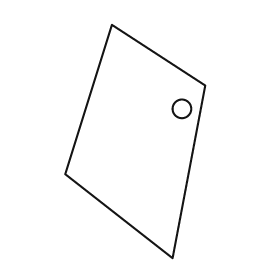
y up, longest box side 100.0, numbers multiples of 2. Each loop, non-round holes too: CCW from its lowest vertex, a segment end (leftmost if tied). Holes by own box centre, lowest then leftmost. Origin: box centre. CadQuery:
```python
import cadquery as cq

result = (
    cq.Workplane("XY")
    .moveTo(16.0, -50.0)
    .lineTo(30.0, 24.0)
    .lineTo(-10.0, 50.0)
    .lineTo(-30.0, -14.0)
    .close()
    .moveTo(20.0, 14.0)
    .circle(4.0)
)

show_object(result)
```